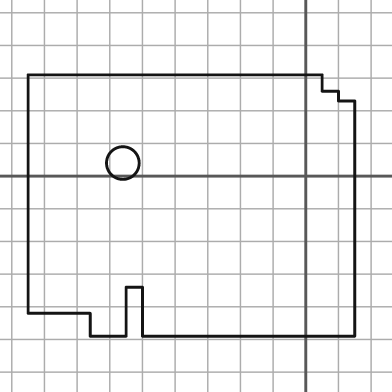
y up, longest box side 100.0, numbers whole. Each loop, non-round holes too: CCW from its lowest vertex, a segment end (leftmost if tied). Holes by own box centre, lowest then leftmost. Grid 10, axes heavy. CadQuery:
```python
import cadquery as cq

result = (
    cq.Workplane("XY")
    .moveTo(-66.0, -49.0)
    .lineTo(-55.0, -49.0)
    .lineTo(-55.0, -34.0)
    .lineTo(-50.0, -34.0)
    .lineTo(-50.0, -49.0)
    .lineTo(15.0, -49.0)
    .lineTo(15.0, 23.0)
    .lineTo(10.0, 23.0)
    .lineTo(10.0, 26.0)
    .lineTo(5.0, 26.0)
    .lineTo(5.0, 31.0)
    .lineTo(-85.0, 31.0)
    .lineTo(-85.0, -42.0)
    .lineTo(-66.0, -42.0)
    .close()
    .moveTo(-56.0, 4.0)
    .circle(5.0)
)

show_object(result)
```